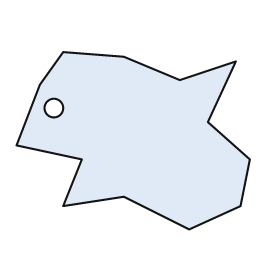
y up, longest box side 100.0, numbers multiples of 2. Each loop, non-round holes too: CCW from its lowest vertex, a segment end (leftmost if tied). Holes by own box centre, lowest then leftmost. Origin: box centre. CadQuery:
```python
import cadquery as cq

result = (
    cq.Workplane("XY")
    .moveTo(24.0, -38.0)
    .lineTo(46.0, -28.0)
    .lineTo(50.0, -8.0)
    .lineTo(32.0, 8.0)
    .lineTo(44.0, 34.0)
    .lineTo(20.0, 26.0)
    .lineTo(-4.0, 36.0)
    .lineTo(-30.0, 38.0)
    .lineTo(-40.0, 24.0)
    .lineTo(-50.0, -2.0)
    .lineTo(-22.0, -8.0)
    .lineTo(-30.0, -28.0)
    .lineTo(-4.0, -24.0)
    .close()
    .moveTo(-34.0, 14.0)
    .circle(4.0)
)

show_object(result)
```